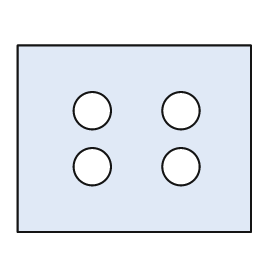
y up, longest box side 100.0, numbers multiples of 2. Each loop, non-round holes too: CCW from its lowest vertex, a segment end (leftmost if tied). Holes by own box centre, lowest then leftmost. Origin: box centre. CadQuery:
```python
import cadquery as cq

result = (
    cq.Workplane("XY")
    .moveTo(-50.0, -40.0)
    .lineTo(50.0, -40.0)
    .lineTo(50.0, 40.0)
    .lineTo(-50.0, 40.0)
    .close()
    .moveTo(-18.0, -12.0)
    .circle(8.0)
    .moveTo(20.0, -12.0)
    .circle(8.0)
    .moveTo(-18.0, 12.0)
    .circle(8.0)
    .moveTo(20.0, 12.0)
    .circle(8.0)
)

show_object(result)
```